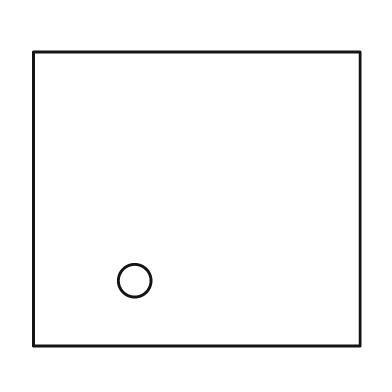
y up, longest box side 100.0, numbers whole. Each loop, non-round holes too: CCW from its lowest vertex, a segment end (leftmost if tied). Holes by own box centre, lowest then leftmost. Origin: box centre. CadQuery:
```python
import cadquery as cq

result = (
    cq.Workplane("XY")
    .moveTo(-50.0, -45.0)
    .lineTo(50.0, -45.0)
    .lineTo(50.0, 45.0)
    .lineTo(-50.0, 45.0)
    .close()
    .moveTo(-19.0, -25.0)
    .circle(5.0)
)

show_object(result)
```